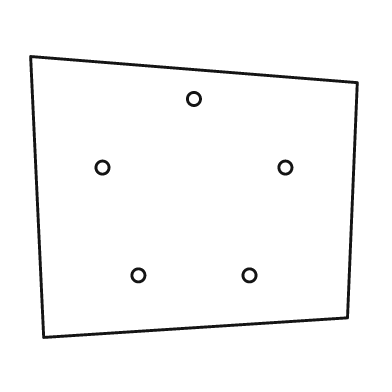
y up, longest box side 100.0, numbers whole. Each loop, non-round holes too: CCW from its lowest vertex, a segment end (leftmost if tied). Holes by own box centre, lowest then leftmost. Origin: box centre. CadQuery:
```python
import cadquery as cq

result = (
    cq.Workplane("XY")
    .moveTo(-46.0, -43.0)
    .lineTo(47.0, -37.0)
    .lineTo(50.0, 35.0)
    .lineTo(-50.0, 43.0)
    .close()
    .moveTo(-17.0, -24.0)
    .circle(2.0)
    .moveTo(17.0, -24.0)
    .circle(2.0)
    .moveTo(-28.0, 9.0)
    .circle(2.0)
    .moveTo(28.0, 9.0)
    .circle(2.0)
    .moveTo(0.0, 30.0)
    .circle(2.0)
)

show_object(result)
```